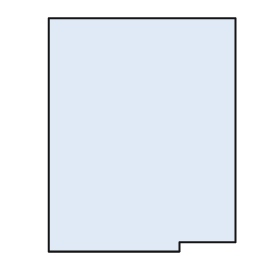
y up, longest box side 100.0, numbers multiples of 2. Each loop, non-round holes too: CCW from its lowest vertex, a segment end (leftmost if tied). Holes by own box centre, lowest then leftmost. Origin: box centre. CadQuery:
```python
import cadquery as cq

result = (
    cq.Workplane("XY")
    .moveTo(-40.0, -50.0)
    .lineTo(16.0, -50.0)
    .lineTo(16.0, -46.0)
    .lineTo(40.0, -46.0)
    .lineTo(40.0, 50.0)
    .lineTo(-40.0, 50.0)
    .close()
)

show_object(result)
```